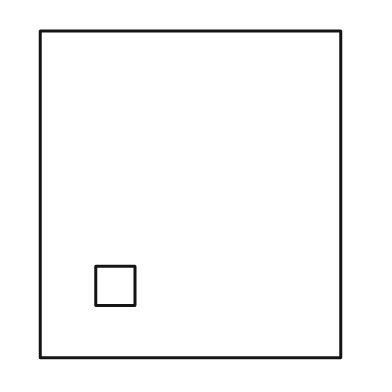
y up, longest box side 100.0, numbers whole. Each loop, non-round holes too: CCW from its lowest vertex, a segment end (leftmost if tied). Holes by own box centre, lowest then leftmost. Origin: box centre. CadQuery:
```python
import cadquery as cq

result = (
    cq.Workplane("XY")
    .moveTo(-46.0, -50.0)
    .lineTo(46.0, -50.0)
    .lineTo(46.0, 50.0)
    .lineTo(-46.0, 50.0)
    .close()
    .moveTo(-29.0, -34.0)
    .lineTo(-17.0, -34.0)
    .lineTo(-17.0, -22.0)
    .lineTo(-29.0, -22.0)
    .close()
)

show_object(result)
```